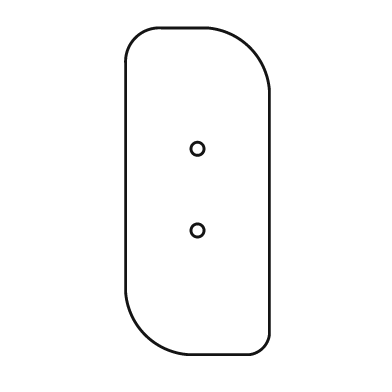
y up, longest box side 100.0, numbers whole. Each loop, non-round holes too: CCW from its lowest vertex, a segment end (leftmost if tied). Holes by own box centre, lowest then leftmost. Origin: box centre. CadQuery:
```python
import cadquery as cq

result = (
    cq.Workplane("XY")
    .moveTo(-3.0, -50.0)
    .lineTo(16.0, -50.0)
    .threePointArc((20.0, -48.0), (22.0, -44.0))
    .lineTo(22.0, 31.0)
    .threePointArc((16.0, 44.0), (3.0, 50.0))
    .lineTo(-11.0, 50.0)
    .threePointArc((-19.0, 47.0), (-22.0, 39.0))
    .lineTo(-22.0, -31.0)
    .threePointArc((-16.0, -44.0), (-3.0, -50.0))
    .close()
    .moveTo(0.0, -12.0)
    .circle(2.0)
    .moveTo(0.0, 13.0)
    .circle(2.0)
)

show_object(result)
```